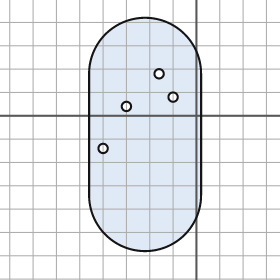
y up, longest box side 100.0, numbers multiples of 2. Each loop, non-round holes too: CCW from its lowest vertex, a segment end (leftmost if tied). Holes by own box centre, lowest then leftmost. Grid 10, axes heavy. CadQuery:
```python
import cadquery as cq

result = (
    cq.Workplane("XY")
    .moveTo(-46.0, -34.0)
    .threePointArc((-22.0, -58.0), (2.0, -34.0))
    .lineTo(2.0, 18.0)
    .threePointArc((-22.0, 42.0), (-46.0, 18.0))
    .close()
    .moveTo(-40.0, -14.0)
    .circle(2.0)
    .moveTo(-30.0, 4.0)
    .circle(2.0)
    .moveTo(-10.0, 8.0)
    .circle(2.0)
    .moveTo(-16.0, 18.0)
    .circle(2.0)
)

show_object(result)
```